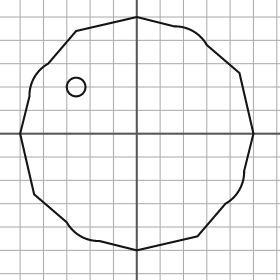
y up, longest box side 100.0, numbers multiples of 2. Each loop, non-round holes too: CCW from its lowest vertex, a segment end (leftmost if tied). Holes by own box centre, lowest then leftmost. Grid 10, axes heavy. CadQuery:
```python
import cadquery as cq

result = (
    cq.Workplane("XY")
    .moveTo(0.0, -50.0)
    .lineTo(26.0, -44.0)
    .lineTo(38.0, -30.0)
    .threePointArc((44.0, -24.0), (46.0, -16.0))
    .lineTo(50.0, 0.0)
    .lineTo(44.0, 26.0)
    .lineTo(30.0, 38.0)
    .threePointArc((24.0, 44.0), (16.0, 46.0))
    .lineTo(0.0, 50.0)
    .lineTo(-26.0, 44.0)
    .lineTo(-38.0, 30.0)
    .threePointArc((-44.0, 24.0), (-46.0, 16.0))
    .lineTo(-50.0, 0.0)
    .lineTo(-44.0, -26.0)
    .lineTo(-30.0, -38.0)
    .threePointArc((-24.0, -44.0), (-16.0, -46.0))
    .close()
    .moveTo(-26.0, 20.0)
    .circle(4.0)
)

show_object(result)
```